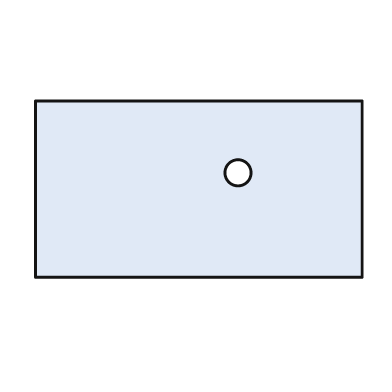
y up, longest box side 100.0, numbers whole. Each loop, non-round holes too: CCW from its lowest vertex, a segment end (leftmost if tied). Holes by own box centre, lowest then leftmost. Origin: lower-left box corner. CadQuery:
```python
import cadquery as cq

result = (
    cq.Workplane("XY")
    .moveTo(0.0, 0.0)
    .lineTo(100.0, 0.0)
    .lineTo(100.0, 54.0)
    .lineTo(0.0, 54.0)
    .close()
    .moveTo(62.0, 32.0)
    .circle(4.0)
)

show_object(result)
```